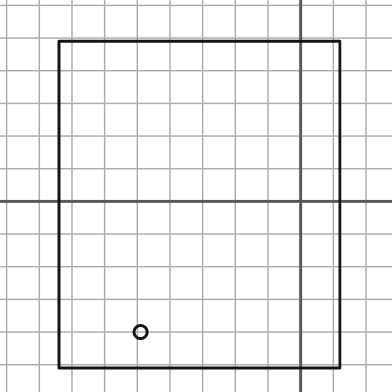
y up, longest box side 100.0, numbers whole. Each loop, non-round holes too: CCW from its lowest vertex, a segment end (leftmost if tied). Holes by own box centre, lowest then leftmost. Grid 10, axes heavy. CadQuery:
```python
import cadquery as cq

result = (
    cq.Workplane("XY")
    .moveTo(-74.0, -51.0)
    .lineTo(12.0, -51.0)
    .lineTo(12.0, 49.0)
    .lineTo(-74.0, 49.0)
    .close()
    .moveTo(-49.0, -40.0)
    .circle(2.0)
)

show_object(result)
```